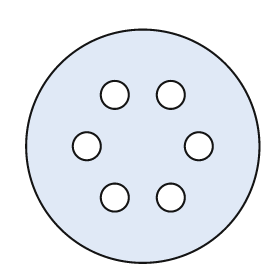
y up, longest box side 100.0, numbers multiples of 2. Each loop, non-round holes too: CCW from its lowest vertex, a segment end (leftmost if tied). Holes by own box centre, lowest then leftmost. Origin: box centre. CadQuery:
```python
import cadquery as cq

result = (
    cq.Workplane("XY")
    .moveTo(0.0, 0.0)
    .circle(50.0)
    .moveTo(-12.0, -22.0)
    .circle(6.0)
    .moveTo(12.0, -22.0)
    .circle(6.0)
    .moveTo(-24.0, 0.0)
    .circle(6.0)
    .moveTo(24.0, 0.0)
    .circle(6.0)
    .moveTo(-12.0, 22.0)
    .circle(6.0)
    .moveTo(12.0, 22.0)
    .circle(6.0)
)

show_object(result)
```